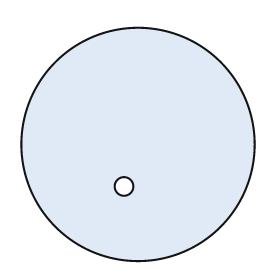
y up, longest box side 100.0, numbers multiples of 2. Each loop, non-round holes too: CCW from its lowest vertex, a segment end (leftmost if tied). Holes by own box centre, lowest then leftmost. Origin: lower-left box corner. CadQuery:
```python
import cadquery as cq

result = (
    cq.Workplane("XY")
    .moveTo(50.0, 50.0)
    .circle(50.0)
    .moveTo(44.0, 32.0)
    .circle(4.0)
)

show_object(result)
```